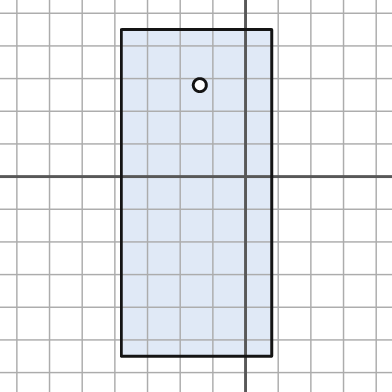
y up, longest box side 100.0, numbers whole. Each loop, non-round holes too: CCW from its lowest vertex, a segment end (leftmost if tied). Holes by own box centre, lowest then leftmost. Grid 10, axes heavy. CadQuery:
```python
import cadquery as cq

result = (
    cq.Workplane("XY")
    .moveTo(-38.0, -55.0)
    .lineTo(8.0, -55.0)
    .lineTo(8.0, 45.0)
    .lineTo(-38.0, 45.0)
    .close()
    .moveTo(-14.0, 28.0)
    .circle(2.0)
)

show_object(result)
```